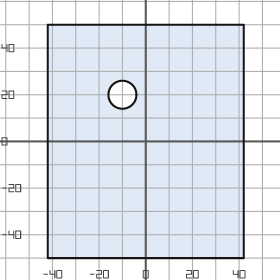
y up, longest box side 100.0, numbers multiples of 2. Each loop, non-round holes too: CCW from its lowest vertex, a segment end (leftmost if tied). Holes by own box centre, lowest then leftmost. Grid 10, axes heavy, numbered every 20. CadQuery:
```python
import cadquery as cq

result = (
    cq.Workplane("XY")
    .moveTo(-42.0, -50.0)
    .lineTo(42.0, -50.0)
    .lineTo(42.0, 50.0)
    .lineTo(-42.0, 50.0)
    .close()
    .moveTo(-10.0, 20.0)
    .circle(6.0)
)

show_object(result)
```